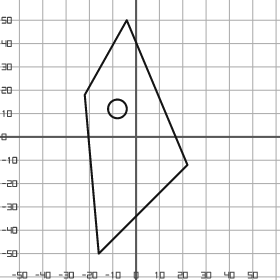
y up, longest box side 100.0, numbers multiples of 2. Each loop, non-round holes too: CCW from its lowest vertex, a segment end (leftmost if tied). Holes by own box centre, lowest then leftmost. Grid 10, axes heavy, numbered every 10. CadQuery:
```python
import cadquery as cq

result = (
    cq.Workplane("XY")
    .moveTo(-16.0, -50.0)
    .lineTo(22.0, -12.0)
    .lineTo(-4.0, 50.0)
    .lineTo(-22.0, 18.0)
    .close()
    .moveTo(-8.0, 12.0)
    .circle(4.0)
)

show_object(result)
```